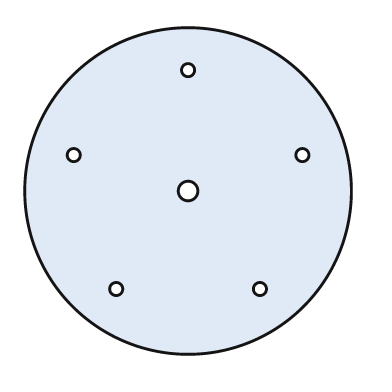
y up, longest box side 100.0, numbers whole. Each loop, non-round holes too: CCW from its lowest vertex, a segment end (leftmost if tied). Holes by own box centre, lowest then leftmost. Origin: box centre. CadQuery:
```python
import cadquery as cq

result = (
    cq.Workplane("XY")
    .moveTo(0.0, 0.0)
    .circle(50.0)
    .moveTo(-22.0, -30.0)
    .circle(2.0)
    .moveTo(22.0, -30.0)
    .circle(2.0)
    .moveTo(0.0, 0.0)
    .circle(3.0)
    .moveTo(-35.0, 11.0)
    .circle(2.0)
    .moveTo(35.0, 11.0)
    .circle(2.0)
    .moveTo(0.0, 37.0)
    .circle(2.0)
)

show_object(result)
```